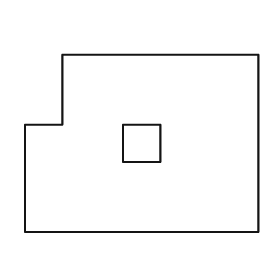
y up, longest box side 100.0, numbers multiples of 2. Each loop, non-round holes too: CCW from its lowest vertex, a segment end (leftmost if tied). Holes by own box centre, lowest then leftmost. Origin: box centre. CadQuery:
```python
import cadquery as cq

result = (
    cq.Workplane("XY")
    .moveTo(-50.0, -38.0)
    .lineTo(50.0, -38.0)
    .lineTo(50.0, 38.0)
    .lineTo(-34.0, 38.0)
    .lineTo(-34.0, 8.0)
    .lineTo(-50.0, 8.0)
    .close()
    .moveTo(-8.0, -8.0)
    .lineTo(8.0, -8.0)
    .lineTo(8.0, 8.0)
    .lineTo(-8.0, 8.0)
    .close()
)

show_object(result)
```